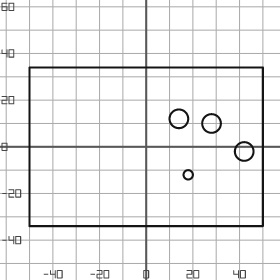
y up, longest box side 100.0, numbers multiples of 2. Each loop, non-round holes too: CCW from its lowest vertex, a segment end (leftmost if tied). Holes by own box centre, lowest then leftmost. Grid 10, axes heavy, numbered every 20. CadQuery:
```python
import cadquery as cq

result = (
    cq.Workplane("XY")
    .moveTo(-50.0, -34.0)
    .lineTo(50.0, -34.0)
    .lineTo(50.0, 34.0)
    .lineTo(-50.0, 34.0)
    .close()
    .moveTo(18.0, -12.0)
    .circle(2.0)
    .moveTo(42.0, -2.0)
    .circle(4.0)
    .moveTo(28.0, 10.0)
    .circle(4.0)
    .moveTo(14.0, 12.0)
    .circle(4.0)
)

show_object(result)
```